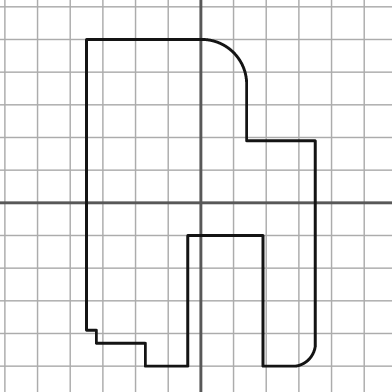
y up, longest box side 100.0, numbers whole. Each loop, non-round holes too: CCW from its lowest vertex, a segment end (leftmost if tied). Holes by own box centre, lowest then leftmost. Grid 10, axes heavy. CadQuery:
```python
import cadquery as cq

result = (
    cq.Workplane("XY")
    .moveTo(-17.0, -50.0)
    .lineTo(-4.0, -50.0)
    .lineTo(-4.0, -10.0)
    .lineTo(19.0, -10.0)
    .lineTo(19.0, -50.0)
    .lineTo(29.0, -50.0)
    .threePointArc((33.0, -48.0), (35.0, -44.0))
    .lineTo(35.0, 19.0)
    .lineTo(14.0, 19.0)
    .lineTo(14.0, 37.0)
    .threePointArc((10.0, 46.0), (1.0, 50.0))
    .lineTo(-35.0, 50.0)
    .lineTo(-35.0, -39.0)
    .lineTo(-32.0, -39.0)
    .lineTo(-32.0, -43.0)
    .lineTo(-17.0, -43.0)
    .close()
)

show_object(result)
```